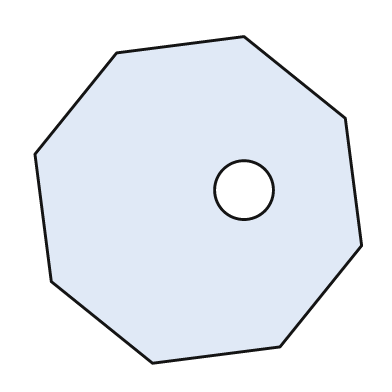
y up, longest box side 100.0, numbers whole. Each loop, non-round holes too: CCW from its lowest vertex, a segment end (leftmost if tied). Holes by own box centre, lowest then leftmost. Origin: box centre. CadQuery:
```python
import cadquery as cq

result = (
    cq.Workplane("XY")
    .moveTo(-14.0, -50.0)
    .lineTo(25.0, -45.0)
    .lineTo(50.0, -14.0)
    .lineTo(45.0, 25.0)
    .lineTo(14.0, 50.0)
    .lineTo(-25.0, 45.0)
    .lineTo(-50.0, 14.0)
    .lineTo(-45.0, -25.0)
    .close()
    .moveTo(14.0, 3.0)
    .circle(9.0)
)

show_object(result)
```